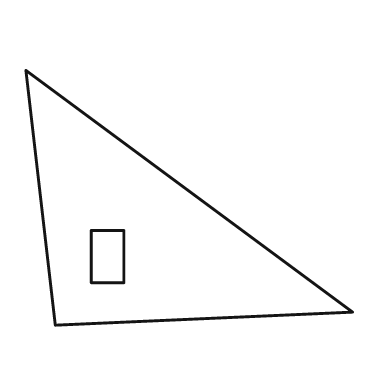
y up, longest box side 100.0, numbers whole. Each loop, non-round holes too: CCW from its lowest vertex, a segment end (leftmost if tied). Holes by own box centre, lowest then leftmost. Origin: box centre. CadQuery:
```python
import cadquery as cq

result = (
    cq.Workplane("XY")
    .moveTo(-41.0, -39.0)
    .lineTo(50.0, -35.0)
    .lineTo(-50.0, 39.0)
    .close()
    .moveTo(-30.0, -26.0)
    .lineTo(-20.0, -26.0)
    .lineTo(-20.0, -10.0)
    .lineTo(-30.0, -10.0)
    .close()
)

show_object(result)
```